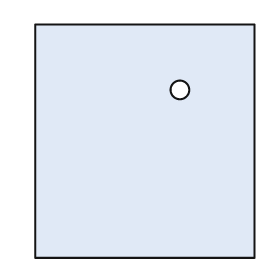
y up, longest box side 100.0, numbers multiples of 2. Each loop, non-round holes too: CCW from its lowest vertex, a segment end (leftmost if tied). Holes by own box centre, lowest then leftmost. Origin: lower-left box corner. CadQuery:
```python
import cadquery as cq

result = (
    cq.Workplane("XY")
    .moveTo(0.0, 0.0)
    .lineTo(94.0, 0.0)
    .lineTo(94.0, 100.0)
    .lineTo(0.0, 100.0)
    .close()
    .moveTo(62.0, 72.0)
    .circle(4.0)
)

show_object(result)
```